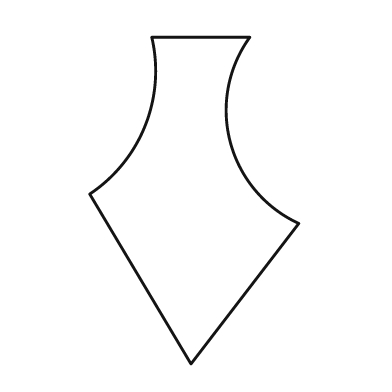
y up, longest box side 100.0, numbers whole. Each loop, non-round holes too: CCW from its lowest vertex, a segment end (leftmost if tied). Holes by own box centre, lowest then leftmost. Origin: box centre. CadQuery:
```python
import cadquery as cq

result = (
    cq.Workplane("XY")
    .moveTo(-1.0, -50.0)
    .lineTo(32.0, -7.0)
    .threePointArc((11.0, 18.0), (17.0, 50.0))
    .lineTo(-13.0, 50.0)
    .threePointArc((-15.0, 23.0), (-32.0, 2.0))
    .close()
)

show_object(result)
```